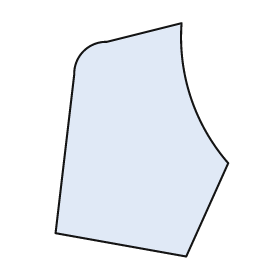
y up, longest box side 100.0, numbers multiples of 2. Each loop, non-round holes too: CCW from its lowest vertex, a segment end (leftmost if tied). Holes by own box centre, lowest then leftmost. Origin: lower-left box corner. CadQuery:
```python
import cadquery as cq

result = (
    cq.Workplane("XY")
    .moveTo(56.0, 0.0)
    .lineTo(74.0, 40.0)
    .threePointArc((58.0, 68.0), (54.0, 100.0))
    .lineTo(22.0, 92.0)
    .threePointArc((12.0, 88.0), (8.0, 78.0))
    .lineTo(0.0, 10.0)
    .close()
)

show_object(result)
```